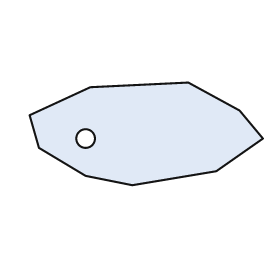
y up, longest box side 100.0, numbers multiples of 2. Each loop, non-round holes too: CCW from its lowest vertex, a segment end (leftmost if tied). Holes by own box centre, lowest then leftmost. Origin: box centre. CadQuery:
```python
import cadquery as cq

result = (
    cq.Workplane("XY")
    .moveTo(-6.0, -22.0)
    .lineTo(30.0, -16.0)
    .lineTo(50.0, -2.0)
    .lineTo(40.0, 10.0)
    .lineTo(18.0, 22.0)
    .lineTo(-24.0, 20.0)
    .lineTo(-50.0, 8.0)
    .lineTo(-46.0, -6.0)
    .lineTo(-26.0, -18.0)
    .close()
    .moveTo(-26.0, -2.0)
    .circle(4.0)
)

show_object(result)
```